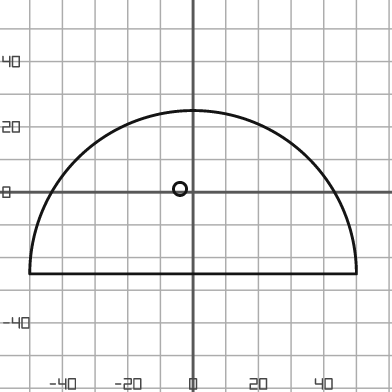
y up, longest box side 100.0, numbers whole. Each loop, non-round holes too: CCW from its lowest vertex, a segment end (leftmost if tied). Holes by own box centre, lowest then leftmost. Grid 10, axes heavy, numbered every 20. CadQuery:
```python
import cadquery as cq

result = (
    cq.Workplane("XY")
    .moveTo(-50.0, -25.0)
    .lineTo(50.0, -25.0)
    .threePointArc((0.0, 25.0), (-50.0, -25.0))
    .close()
    .moveTo(-4.0, 1.0)
    .circle(2.0)
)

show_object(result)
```